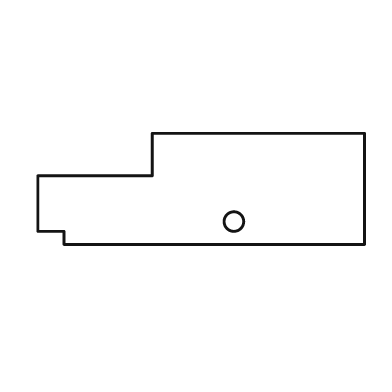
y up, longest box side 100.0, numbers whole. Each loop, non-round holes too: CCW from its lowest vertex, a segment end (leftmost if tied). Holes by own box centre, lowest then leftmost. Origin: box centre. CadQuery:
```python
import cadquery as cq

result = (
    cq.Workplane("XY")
    .moveTo(-42.0, -17.0)
    .lineTo(50.0, -17.0)
    .lineTo(50.0, 17.0)
    .lineTo(-15.0, 17.0)
    .lineTo(-15.0, 4.0)
    .lineTo(-50.0, 4.0)
    .lineTo(-50.0, -13.0)
    .lineTo(-42.0, -13.0)
    .close()
    .moveTo(10.0, -10.0)
    .circle(3.0)
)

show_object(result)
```